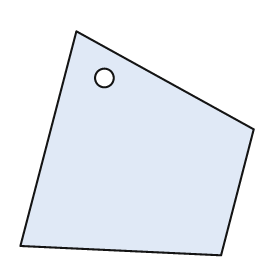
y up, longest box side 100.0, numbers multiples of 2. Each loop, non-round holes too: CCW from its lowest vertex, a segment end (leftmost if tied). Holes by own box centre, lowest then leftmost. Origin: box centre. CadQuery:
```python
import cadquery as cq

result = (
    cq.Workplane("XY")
    .moveTo(36.0, -48.0)
    .lineTo(50.0, 6.0)
    .lineTo(-26.0, 48.0)
    .lineTo(-50.0, -44.0)
    .close()
    .moveTo(-14.0, 28.0)
    .circle(4.0)
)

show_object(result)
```